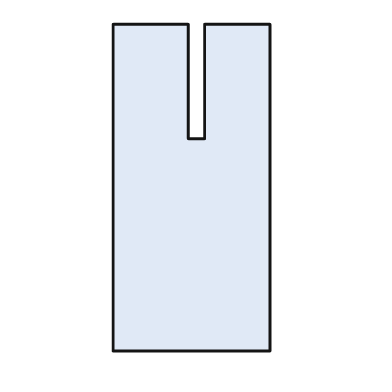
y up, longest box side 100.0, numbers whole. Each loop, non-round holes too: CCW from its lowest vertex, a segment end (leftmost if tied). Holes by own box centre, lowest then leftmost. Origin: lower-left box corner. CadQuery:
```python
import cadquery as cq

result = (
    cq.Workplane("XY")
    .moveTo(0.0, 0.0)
    .lineTo(48.0, 0.0)
    .lineTo(48.0, 100.0)
    .lineTo(28.0, 100.0)
    .lineTo(28.0, 65.0)
    .lineTo(23.0, 65.0)
    .lineTo(23.0, 100.0)
    .lineTo(0.0, 100.0)
    .close()
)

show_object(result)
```